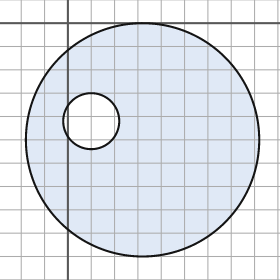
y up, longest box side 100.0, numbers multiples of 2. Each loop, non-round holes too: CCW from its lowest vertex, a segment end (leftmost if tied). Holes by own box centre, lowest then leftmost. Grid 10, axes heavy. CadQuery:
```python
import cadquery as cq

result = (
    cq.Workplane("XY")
    .moveTo(32.0, -50.0)
    .circle(50.0)
    .moveTo(10.0, -42.0)
    .circle(12.0)
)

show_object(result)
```